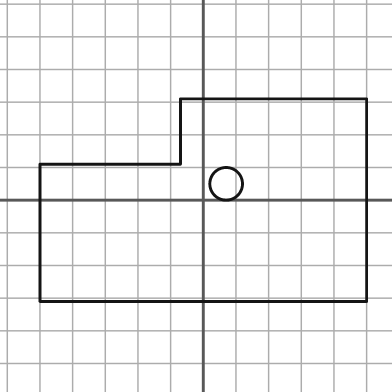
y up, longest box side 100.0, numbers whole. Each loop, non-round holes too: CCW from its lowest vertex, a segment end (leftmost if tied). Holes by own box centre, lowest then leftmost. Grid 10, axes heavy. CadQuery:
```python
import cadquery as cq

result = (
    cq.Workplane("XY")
    .moveTo(-50.0, -31.0)
    .lineTo(50.0, -31.0)
    .lineTo(50.0, 31.0)
    .lineTo(-7.0, 31.0)
    .lineTo(-7.0, 11.0)
    .lineTo(-50.0, 11.0)
    .close()
    .moveTo(7.0, 5.0)
    .circle(5.0)
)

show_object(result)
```